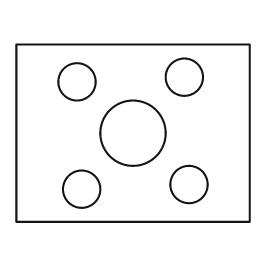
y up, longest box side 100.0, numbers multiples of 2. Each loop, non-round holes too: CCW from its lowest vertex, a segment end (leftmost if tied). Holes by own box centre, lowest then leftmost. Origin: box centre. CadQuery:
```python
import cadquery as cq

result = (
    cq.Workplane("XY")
    .moveTo(-50.0, -38.0)
    .lineTo(50.0, -38.0)
    .lineTo(50.0, 38.0)
    .lineTo(-50.0, 38.0)
    .close()
    .moveTo(-22.0, -24.0)
    .circle(8.0)
    .moveTo(24.0, -22.0)
    .circle(8.0)
    .moveTo(0.0, 0.0)
    .circle(14.0)
    .moveTo(-24.0, 22.0)
    .circle(8.0)
    .moveTo(22.0, 24.0)
    .circle(8.0)
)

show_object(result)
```